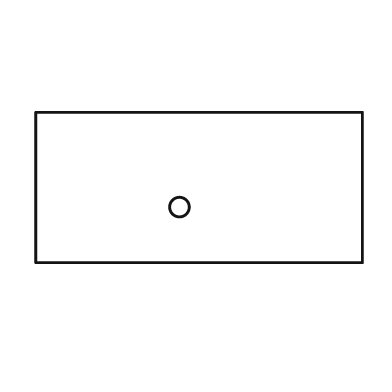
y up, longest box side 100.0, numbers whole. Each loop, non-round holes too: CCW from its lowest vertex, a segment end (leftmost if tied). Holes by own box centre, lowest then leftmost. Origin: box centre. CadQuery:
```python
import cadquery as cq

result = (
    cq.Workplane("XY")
    .moveTo(-50.0, -23.0)
    .lineTo(50.0, -23.0)
    .lineTo(50.0, 23.0)
    .lineTo(-50.0, 23.0)
    .close()
    .moveTo(-6.0, -6.0)
    .circle(3.0)
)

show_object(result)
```